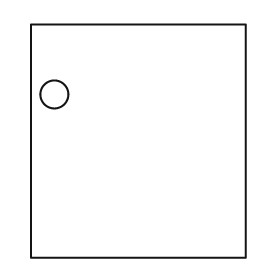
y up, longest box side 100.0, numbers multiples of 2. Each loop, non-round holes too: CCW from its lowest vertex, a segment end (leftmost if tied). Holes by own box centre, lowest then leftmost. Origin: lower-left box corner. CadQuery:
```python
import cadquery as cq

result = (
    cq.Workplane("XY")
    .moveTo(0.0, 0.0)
    .lineTo(92.0, 0.0)
    .lineTo(92.0, 100.0)
    .lineTo(0.0, 100.0)
    .close()
    .moveTo(10.0, 70.0)
    .circle(6.0)
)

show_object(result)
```